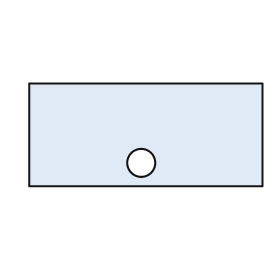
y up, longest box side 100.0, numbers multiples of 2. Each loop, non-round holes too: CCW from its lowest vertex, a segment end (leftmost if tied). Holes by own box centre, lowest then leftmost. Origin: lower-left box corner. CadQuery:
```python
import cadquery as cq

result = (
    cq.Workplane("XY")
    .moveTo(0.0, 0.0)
    .lineTo(100.0, 0.0)
    .lineTo(100.0, 44.0)
    .lineTo(0.0, 44.0)
    .close()
    .moveTo(48.0, 10.0)
    .circle(6.0)
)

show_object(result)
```